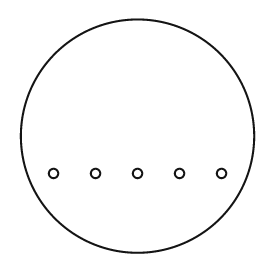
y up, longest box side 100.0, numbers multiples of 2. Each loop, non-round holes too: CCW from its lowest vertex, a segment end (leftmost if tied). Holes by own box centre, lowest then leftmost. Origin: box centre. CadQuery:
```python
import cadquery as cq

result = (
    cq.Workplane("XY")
    .moveTo(0.0, 0.0)
    .circle(50.0)
    .moveTo(-36.0, -16.0)
    .circle(2.0)
    .moveTo(-18.0, -16.0)
    .circle(2.0)
    .moveTo(0.0, -16.0)
    .circle(2.0)
    .moveTo(18.0, -16.0)
    .circle(2.0)
    .moveTo(36.0, -16.0)
    .circle(2.0)
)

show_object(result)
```